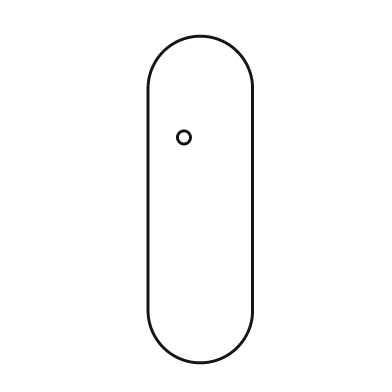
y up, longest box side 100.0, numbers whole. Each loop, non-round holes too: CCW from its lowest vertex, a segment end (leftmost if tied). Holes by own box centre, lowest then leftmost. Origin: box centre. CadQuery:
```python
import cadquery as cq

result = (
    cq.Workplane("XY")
    .moveTo(-16.0, -34.0)
    .threePointArc((0.0, -50.0), (16.0, -34.0))
    .lineTo(16.0, 34.0)
    .threePointArc((0.0, 50.0), (-16.0, 34.0))
    .close()
    .moveTo(-5.0, 19.0)
    .circle(2.0)
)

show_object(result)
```